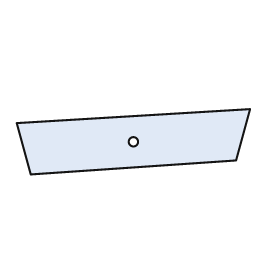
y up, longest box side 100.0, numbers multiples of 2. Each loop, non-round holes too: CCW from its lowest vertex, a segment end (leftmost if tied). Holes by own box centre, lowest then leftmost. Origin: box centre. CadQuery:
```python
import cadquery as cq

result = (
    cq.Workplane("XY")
    .moveTo(-44.0, -14.0)
    .lineTo(44.0, -8.0)
    .lineTo(50.0, 14.0)
    .lineTo(-50.0, 8.0)
    .close()
    .moveTo(0.0, 0.0)
    .circle(2.0)
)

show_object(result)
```